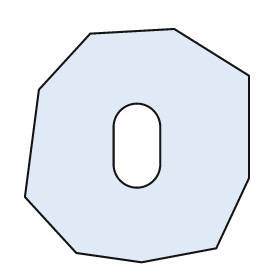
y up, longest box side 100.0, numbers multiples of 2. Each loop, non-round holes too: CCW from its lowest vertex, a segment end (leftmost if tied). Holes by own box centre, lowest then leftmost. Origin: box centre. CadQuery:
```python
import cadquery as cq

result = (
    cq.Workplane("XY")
    .moveTo(2.0, -50.0)
    .lineTo(34.0, -44.0)
    .lineTo(48.0, -14.0)
    .lineTo(48.0, 30.0)
    .lineTo(16.0, 50.0)
    .lineTo(-20.0, 48.0)
    .lineTo(-42.0, 24.0)
    .lineTo(-48.0, -22.0)
    .lineTo(-26.0, -46.0)
    .close()
    .moveTo(-10.0, -8.0)
    .threePointArc((0.0, -18.0), (10.0, -8.0))
    .lineTo(10.0, 8.0)
    .threePointArc((0.0, 18.0), (-10.0, 8.0))
    .close()
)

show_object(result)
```